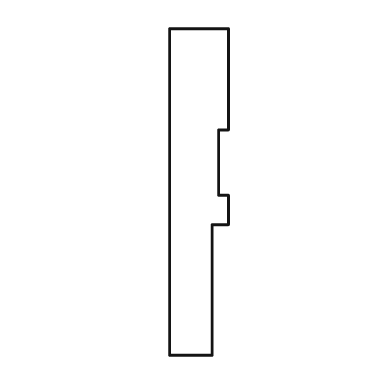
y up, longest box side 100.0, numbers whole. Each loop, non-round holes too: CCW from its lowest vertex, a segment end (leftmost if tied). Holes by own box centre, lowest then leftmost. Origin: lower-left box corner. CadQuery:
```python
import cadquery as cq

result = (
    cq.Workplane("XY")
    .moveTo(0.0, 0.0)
    .lineTo(13.0, 0.0)
    .lineTo(13.0, 40.0)
    .lineTo(18.0, 40.0)
    .lineTo(18.0, 49.0)
    .lineTo(15.0, 49.0)
    .lineTo(15.0, 69.0)
    .lineTo(18.0, 69.0)
    .lineTo(18.0, 100.0)
    .lineTo(0.0, 100.0)
    .close()
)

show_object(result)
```